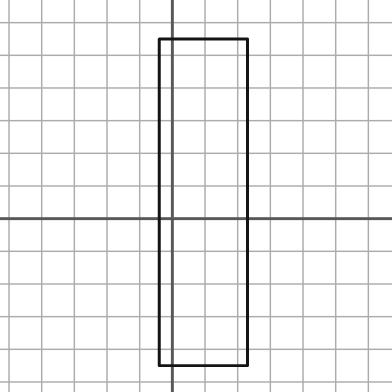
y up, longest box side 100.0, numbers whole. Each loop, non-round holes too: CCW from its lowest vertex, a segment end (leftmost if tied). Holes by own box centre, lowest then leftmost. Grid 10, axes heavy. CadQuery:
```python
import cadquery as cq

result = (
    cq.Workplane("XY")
    .moveTo(-4.0, -45.0)
    .lineTo(23.0, -45.0)
    .lineTo(23.0, 55.0)
    .lineTo(-4.0, 55.0)
    .close()
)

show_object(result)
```